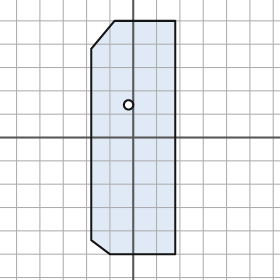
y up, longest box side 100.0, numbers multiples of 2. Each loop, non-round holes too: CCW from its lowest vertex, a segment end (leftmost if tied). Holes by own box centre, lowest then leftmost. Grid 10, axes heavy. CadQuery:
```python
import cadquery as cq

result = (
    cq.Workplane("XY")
    .moveTo(-10.0, -50.0)
    .lineTo(18.0, -50.0)
    .lineTo(18.0, 50.0)
    .lineTo(-8.0, 50.0)
    .lineTo(-18.0, 38.0)
    .lineTo(-18.0, -44.0)
    .close()
    .moveTo(-2.0, 14.0)
    .circle(2.0)
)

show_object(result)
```